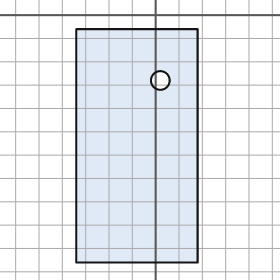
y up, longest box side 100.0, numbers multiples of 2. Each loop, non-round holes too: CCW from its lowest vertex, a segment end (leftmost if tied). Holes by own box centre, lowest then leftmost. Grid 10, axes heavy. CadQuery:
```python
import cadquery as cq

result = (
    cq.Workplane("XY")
    .moveTo(-34.0, -106.0)
    .lineTo(18.0, -106.0)
    .lineTo(18.0, -6.0)
    .lineTo(-34.0, -6.0)
    .close()
    .moveTo(2.0, -28.0)
    .circle(4.0)
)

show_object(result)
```